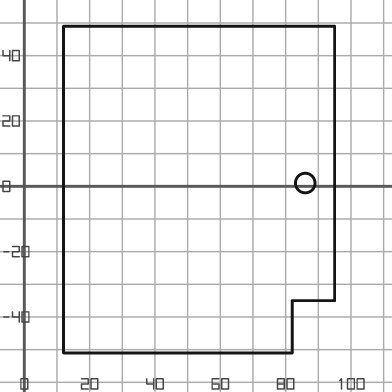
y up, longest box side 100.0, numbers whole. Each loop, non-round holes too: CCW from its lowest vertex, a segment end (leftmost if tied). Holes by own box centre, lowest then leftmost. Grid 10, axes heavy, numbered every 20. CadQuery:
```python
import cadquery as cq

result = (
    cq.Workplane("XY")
    .moveTo(12.0, -51.0)
    .lineTo(82.0, -51.0)
    .lineTo(82.0, -35.0)
    .lineTo(95.0, -35.0)
    .lineTo(95.0, 49.0)
    .lineTo(12.0, 49.0)
    .close()
    .moveTo(86.0, 1.0)
    .circle(3.0)
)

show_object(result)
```